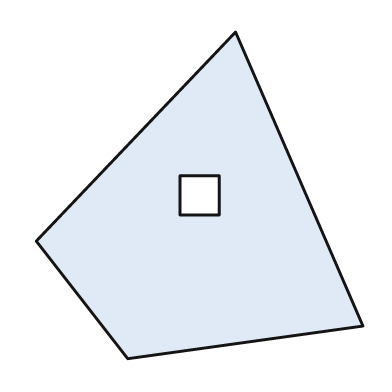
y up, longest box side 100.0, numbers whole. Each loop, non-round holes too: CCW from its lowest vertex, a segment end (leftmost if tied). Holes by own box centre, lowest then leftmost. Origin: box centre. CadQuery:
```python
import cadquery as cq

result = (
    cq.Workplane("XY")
    .moveTo(-22.0, -50.0)
    .lineTo(50.0, -40.0)
    .lineTo(11.0, 50.0)
    .lineTo(-50.0, -14.0)
    .close()
    .moveTo(-6.0, -6.0)
    .lineTo(6.0, -6.0)
    .lineTo(6.0, 6.0)
    .lineTo(-6.0, 6.0)
    .close()
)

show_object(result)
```